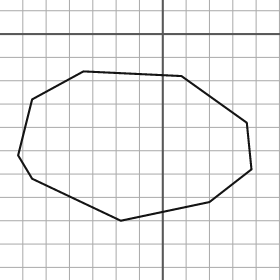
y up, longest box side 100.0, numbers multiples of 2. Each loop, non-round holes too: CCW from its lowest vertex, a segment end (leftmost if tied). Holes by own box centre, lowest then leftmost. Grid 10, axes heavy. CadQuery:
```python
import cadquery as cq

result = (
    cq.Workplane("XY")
    .moveTo(-18.0, -80.0)
    .lineTo(20.0, -72.0)
    .lineTo(38.0, -58.0)
    .lineTo(36.0, -38.0)
    .lineTo(8.0, -18.0)
    .lineTo(-34.0, -16.0)
    .lineTo(-56.0, -28.0)
    .lineTo(-62.0, -52.0)
    .lineTo(-56.0, -62.0)
    .close()
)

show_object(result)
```